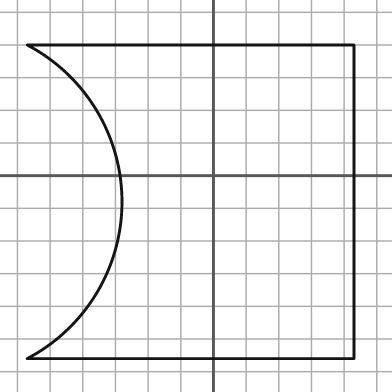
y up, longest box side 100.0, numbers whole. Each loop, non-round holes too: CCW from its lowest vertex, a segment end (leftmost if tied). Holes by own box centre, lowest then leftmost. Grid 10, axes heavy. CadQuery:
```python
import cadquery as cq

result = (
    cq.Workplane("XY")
    .moveTo(-57.0, -56.0)
    .lineTo(43.0, -56.0)
    .lineTo(43.0, 40.0)
    .lineTo(-57.0, 40.0)
    .threePointArc((-28.0, -8.0), (-57.0, -56.0))
    .close()
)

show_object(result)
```